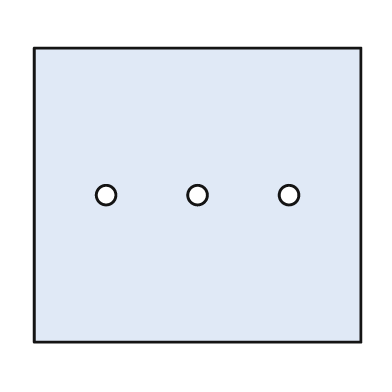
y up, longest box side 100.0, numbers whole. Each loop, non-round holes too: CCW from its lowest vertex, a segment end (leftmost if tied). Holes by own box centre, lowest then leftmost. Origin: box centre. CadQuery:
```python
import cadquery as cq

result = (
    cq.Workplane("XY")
    .moveTo(-50.0, -45.0)
    .lineTo(50.0, -45.0)
    .lineTo(50.0, 45.0)
    .lineTo(-50.0, 45.0)
    .close()
    .moveTo(-28.0, 0.0)
    .circle(3.0)
    .moveTo(0.0, 0.0)
    .circle(3.0)
    .moveTo(28.0, 0.0)
    .circle(3.0)
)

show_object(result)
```